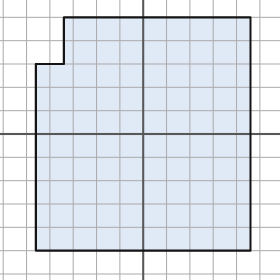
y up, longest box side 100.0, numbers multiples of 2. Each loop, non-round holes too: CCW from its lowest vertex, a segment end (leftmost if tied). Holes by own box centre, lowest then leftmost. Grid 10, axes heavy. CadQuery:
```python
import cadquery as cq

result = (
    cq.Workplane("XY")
    .moveTo(-46.0, -50.0)
    .lineTo(46.0, -50.0)
    .lineTo(46.0, 50.0)
    .lineTo(-34.0, 50.0)
    .lineTo(-34.0, 30.0)
    .lineTo(-46.0, 30.0)
    .close()
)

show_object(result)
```